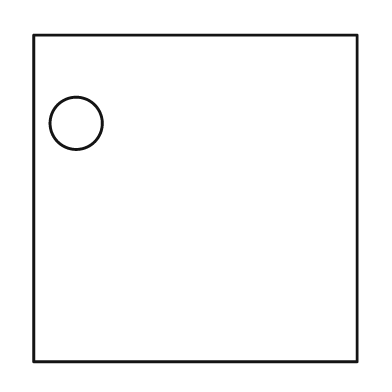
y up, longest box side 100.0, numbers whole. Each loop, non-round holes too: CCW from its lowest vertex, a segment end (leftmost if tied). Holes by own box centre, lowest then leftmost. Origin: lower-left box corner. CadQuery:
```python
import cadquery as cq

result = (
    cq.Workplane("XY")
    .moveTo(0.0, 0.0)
    .lineTo(99.0, 0.0)
    .lineTo(99.0, 100.0)
    .lineTo(0.0, 100.0)
    .close()
    .moveTo(13.0, 73.0)
    .circle(8.0)
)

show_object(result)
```